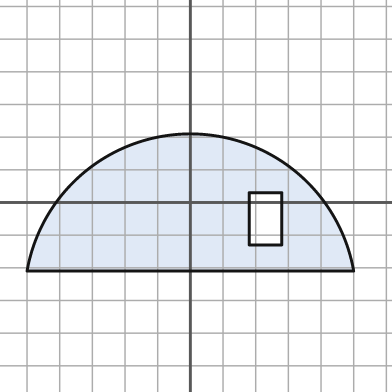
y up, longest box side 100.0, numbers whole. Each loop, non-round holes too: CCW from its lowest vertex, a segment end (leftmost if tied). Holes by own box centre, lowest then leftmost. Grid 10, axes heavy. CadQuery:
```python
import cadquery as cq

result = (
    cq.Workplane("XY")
    .moveTo(-50.0, -21.0)
    .lineTo(50.0, -21.0)
    .threePointArc((0.0, 21.0), (-50.0, -21.0))
    .close()
    .moveTo(18.0, -13.0)
    .lineTo(28.0, -13.0)
    .lineTo(28.0, 3.0)
    .lineTo(18.0, 3.0)
    .close()
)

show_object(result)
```